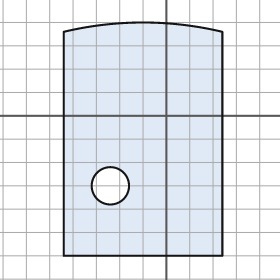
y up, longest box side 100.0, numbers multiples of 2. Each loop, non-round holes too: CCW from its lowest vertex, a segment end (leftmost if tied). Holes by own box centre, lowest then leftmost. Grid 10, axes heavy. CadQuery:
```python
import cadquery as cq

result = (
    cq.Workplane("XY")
    .moveTo(-44.0, -60.0)
    .lineTo(24.0, -60.0)
    .lineTo(24.0, 36.0)
    .threePointArc((-10.0, 40.0), (-44.0, 36.0))
    .close()
    .moveTo(-24.0, -30.0)
    .circle(8.0)
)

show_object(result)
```